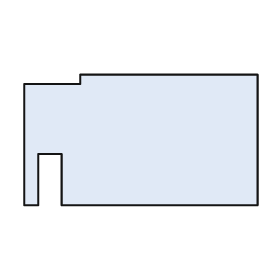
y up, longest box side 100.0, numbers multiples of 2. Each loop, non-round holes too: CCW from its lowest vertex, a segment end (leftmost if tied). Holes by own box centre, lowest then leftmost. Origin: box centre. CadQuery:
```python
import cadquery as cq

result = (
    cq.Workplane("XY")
    .moveTo(-50.0, -28.0)
    .lineTo(-44.0, -28.0)
    .lineTo(-44.0, -6.0)
    .lineTo(-34.0, -6.0)
    .lineTo(-34.0, -28.0)
    .lineTo(50.0, -28.0)
    .lineTo(50.0, 28.0)
    .lineTo(-26.0, 28.0)
    .lineTo(-26.0, 24.0)
    .lineTo(-50.0, 24.0)
    .close()
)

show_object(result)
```